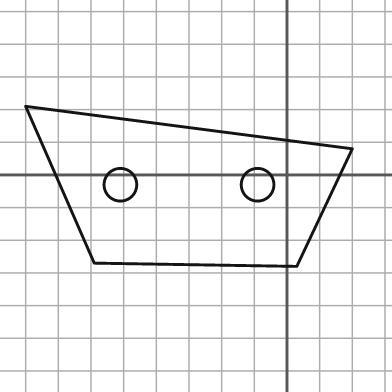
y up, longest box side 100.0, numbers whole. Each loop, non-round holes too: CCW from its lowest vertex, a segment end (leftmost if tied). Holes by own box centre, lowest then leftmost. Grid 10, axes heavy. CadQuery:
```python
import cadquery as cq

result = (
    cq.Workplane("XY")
    .moveTo(3.0, -28.0)
    .lineTo(20.0, 8.0)
    .lineTo(-80.0, 21.0)
    .lineTo(-59.0, -27.0)
    .close()
    .moveTo(-51.0, -3.0)
    .circle(5.0)
    .moveTo(-9.0, -3.0)
    .circle(5.0)
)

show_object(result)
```